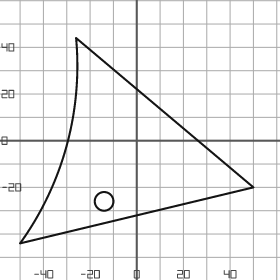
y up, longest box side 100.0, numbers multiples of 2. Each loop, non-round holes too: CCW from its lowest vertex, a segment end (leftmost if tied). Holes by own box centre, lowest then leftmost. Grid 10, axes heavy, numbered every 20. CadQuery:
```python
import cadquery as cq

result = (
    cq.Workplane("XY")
    .moveTo(-50.0, -44.0)
    .lineTo(50.0, -20.0)
    .lineTo(-26.0, 44.0)
    .threePointArc((-30.0, -2.0), (-50.0, -44.0))
    .close()
    .moveTo(-14.0, -26.0)
    .circle(4.0)
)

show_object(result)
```